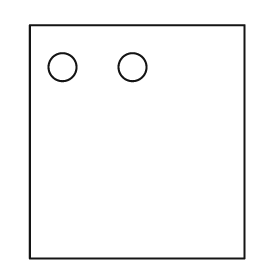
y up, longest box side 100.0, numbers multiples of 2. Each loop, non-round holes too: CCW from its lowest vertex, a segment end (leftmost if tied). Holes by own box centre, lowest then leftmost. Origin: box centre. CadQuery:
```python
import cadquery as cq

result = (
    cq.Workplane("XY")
    .moveTo(-46.0, -50.0)
    .lineTo(46.0, -50.0)
    .lineTo(46.0, 50.0)
    .lineTo(-46.0, 50.0)
    .close()
    .moveTo(-32.0, 32.0)
    .circle(6.0)
    .moveTo(-2.0, 32.0)
    .circle(6.0)
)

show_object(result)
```